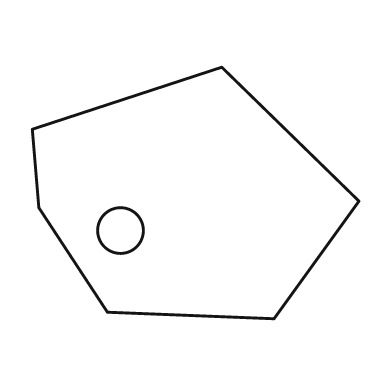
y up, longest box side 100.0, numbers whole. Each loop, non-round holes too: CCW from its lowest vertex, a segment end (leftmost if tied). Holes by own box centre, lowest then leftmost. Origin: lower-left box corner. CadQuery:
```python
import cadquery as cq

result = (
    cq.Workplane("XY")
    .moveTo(74.0, 0.0)
    .lineTo(100.0, 36.0)
    .lineTo(58.0, 77.0)
    .lineTo(0.0, 58.0)
    .lineTo(2.0, 34.0)
    .lineTo(23.0, 2.0)
    .close()
    .moveTo(27.0, 27.0)
    .circle(7.0)
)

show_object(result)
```